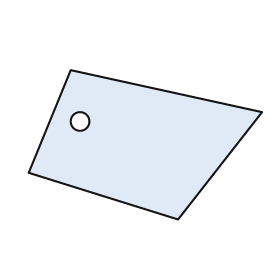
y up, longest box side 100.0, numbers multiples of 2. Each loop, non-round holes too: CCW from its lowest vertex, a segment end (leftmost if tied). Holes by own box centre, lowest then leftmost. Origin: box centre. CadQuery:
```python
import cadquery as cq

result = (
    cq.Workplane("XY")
    .moveTo(14.0, -32.0)
    .lineTo(50.0, 14.0)
    .lineTo(-32.0, 32.0)
    .lineTo(-50.0, -12.0)
    .close()
    .moveTo(-28.0, 10.0)
    .circle(4.0)
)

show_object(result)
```